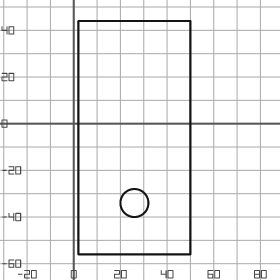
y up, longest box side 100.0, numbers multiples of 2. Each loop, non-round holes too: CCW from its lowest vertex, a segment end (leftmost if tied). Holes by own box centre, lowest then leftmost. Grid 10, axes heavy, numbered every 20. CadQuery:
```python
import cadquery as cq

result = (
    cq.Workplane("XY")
    .moveTo(2.0, -56.0)
    .lineTo(50.0, -56.0)
    .lineTo(50.0, 44.0)
    .lineTo(2.0, 44.0)
    .close()
    .moveTo(26.0, -34.0)
    .circle(6.0)
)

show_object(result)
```